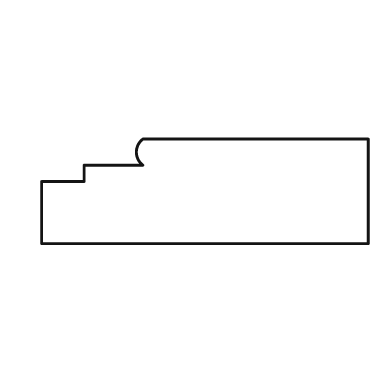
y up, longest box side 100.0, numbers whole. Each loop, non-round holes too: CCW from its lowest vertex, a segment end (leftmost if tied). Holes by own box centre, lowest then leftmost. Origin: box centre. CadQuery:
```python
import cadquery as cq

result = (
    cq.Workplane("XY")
    .moveTo(-50.0, -16.0)
    .lineTo(50.0, -16.0)
    .lineTo(50.0, 16.0)
    .lineTo(-19.0, 16.0)
    .threePointArc((-21.0, 12.0), (-19.0, 8.0))
    .lineTo(-37.0, 8.0)
    .lineTo(-37.0, 3.0)
    .lineTo(-50.0, 3.0)
    .close()
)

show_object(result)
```